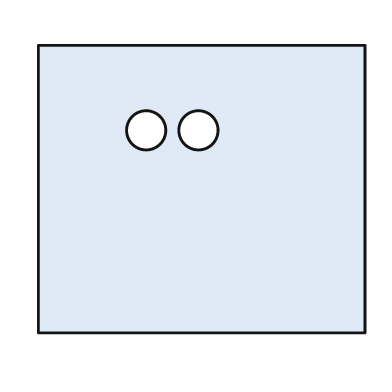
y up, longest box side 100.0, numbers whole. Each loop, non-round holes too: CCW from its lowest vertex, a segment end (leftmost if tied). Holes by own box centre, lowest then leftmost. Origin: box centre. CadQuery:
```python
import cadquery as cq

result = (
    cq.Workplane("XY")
    .moveTo(-50.0, -44.0)
    .lineTo(50.0, -44.0)
    .lineTo(50.0, 44.0)
    .lineTo(-50.0, 44.0)
    .close()
    .moveTo(-17.0, 18.0)
    .circle(6.0)
    .moveTo(-1.0, 18.0)
    .circle(6.0)
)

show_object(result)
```